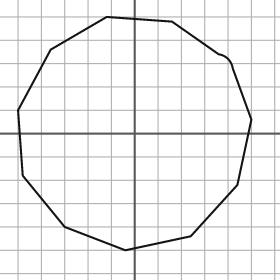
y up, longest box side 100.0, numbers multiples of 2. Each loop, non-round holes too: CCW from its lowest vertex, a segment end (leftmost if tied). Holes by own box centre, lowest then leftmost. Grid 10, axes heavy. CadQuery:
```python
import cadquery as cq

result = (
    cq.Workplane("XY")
    .moveTo(-4.0, -50.0)
    .lineTo(24.0, -44.0)
    .lineTo(44.0, -22.0)
    .lineTo(50.0, 6.0)
    .lineTo(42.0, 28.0)
    .threePointArc((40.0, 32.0), (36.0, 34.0))
    .lineTo(16.0, 48.0)
    .lineTo(-12.0, 50.0)
    .lineTo(-36.0, 36.0)
    .lineTo(-50.0, 10.0)
    .lineTo(-48.0, -18.0)
    .lineTo(-30.0, -40.0)
    .close()
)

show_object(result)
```